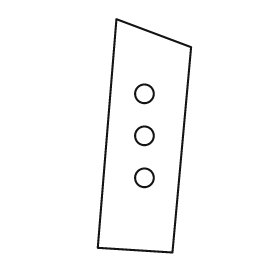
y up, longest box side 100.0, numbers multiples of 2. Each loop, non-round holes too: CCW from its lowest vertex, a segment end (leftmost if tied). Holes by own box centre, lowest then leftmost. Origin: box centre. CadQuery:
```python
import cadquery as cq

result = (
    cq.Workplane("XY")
    .moveTo(12.0, -50.0)
    .lineTo(20.0, 38.0)
    .lineTo(-12.0, 50.0)
    .lineTo(-20.0, -48.0)
    .close()
    .moveTo(0.0, -18.0)
    .circle(4.0)
    .moveTo(0.0, 0.0)
    .circle(4.0)
    .moveTo(0.0, 18.0)
    .circle(4.0)
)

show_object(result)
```